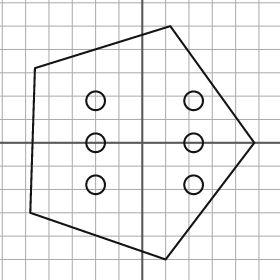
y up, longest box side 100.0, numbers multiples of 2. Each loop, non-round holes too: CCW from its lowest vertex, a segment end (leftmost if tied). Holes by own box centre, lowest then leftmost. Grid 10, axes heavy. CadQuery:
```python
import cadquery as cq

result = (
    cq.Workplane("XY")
    .moveTo(10.0, -50.0)
    .lineTo(48.0, 0.0)
    .lineTo(12.0, 50.0)
    .lineTo(-46.0, 32.0)
    .lineTo(-48.0, -30.0)
    .close()
    .moveTo(-20.0, -18.0)
    .circle(4.0)
    .moveTo(22.0, -18.0)
    .circle(4.0)
    .moveTo(-20.0, 0.0)
    .circle(4.0)
    .moveTo(22.0, 0.0)
    .circle(4.0)
    .moveTo(-20.0, 18.0)
    .circle(4.0)
    .moveTo(22.0, 18.0)
    .circle(4.0)
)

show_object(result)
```